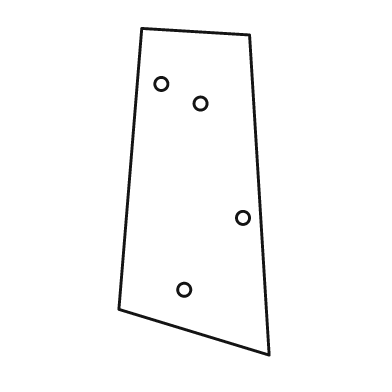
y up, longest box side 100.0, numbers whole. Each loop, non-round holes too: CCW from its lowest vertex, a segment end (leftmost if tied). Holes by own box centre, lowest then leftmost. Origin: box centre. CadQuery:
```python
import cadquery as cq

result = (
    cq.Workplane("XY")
    .moveTo(23.0, -50.0)
    .lineTo(17.0, 48.0)
    .lineTo(-16.0, 50.0)
    .lineTo(-23.0, -36.0)
    .close()
    .moveTo(-3.0, -30.0)
    .circle(2.0)
    .moveTo(15.0, -8.0)
    .circle(2.0)
    .moveTo(2.0, 27.0)
    .circle(2.0)
    .moveTo(-10.0, 33.0)
    .circle(2.0)
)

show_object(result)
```